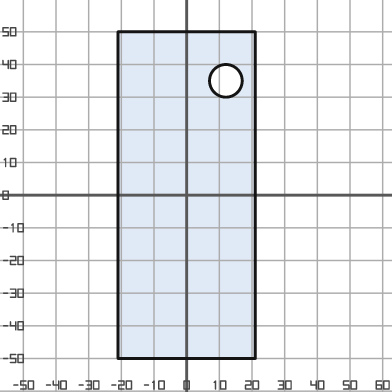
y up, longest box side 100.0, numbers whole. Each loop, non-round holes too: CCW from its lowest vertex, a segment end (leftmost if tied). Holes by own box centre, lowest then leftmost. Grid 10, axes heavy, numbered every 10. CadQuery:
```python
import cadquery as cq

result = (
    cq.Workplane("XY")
    .moveTo(-21.0, -50.0)
    .lineTo(21.0, -50.0)
    .lineTo(21.0, 50.0)
    .lineTo(-21.0, 50.0)
    .close()
    .moveTo(12.0, 35.0)
    .circle(5.0)
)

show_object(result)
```